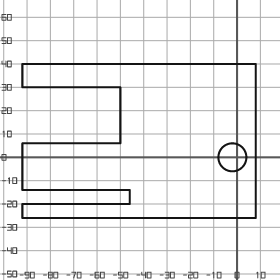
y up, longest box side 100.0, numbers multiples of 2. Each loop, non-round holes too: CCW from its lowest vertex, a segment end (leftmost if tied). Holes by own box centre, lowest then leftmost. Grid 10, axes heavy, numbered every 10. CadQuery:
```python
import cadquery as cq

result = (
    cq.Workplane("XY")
    .moveTo(-92.0, -26.0)
    .lineTo(8.0, -26.0)
    .lineTo(8.0, 40.0)
    .lineTo(-92.0, 40.0)
    .lineTo(-92.0, 30.0)
    .lineTo(-50.0, 30.0)
    .lineTo(-50.0, 6.0)
    .lineTo(-92.0, 6.0)
    .lineTo(-92.0, -14.0)
    .lineTo(-46.0, -14.0)
    .lineTo(-46.0, -20.0)
    .lineTo(-92.0, -20.0)
    .close()
    .moveTo(-2.0, 0.0)
    .circle(6.0)
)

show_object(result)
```